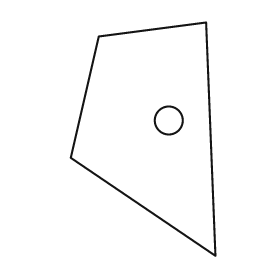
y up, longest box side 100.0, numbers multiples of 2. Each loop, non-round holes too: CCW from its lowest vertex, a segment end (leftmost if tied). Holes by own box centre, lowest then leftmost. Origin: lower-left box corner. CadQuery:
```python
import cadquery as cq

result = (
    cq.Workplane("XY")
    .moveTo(62.0, 0.0)
    .lineTo(58.0, 100.0)
    .lineTo(12.0, 94.0)
    .lineTo(0.0, 42.0)
    .close()
    .moveTo(42.0, 58.0)
    .circle(6.0)
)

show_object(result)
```